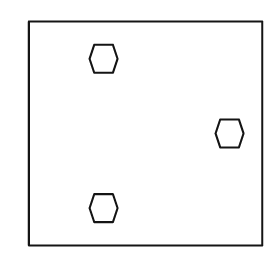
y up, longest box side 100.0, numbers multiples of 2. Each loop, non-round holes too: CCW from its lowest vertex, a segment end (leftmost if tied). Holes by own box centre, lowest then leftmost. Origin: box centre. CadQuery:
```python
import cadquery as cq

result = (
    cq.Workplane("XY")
    .moveTo(-50.0, -48.0)
    .lineTo(50.0, -48.0)
    .lineTo(50.0, 48.0)
    .lineTo(-50.0, 48.0)
    .close()
    .moveTo(-22.0, -38.0)
    .lineTo(-14.0, -38.0)
    .lineTo(-12.0, -32.0)
    .lineTo(-14.0, -26.0)
    .lineTo(-22.0, -26.0)
    .lineTo(-24.0, -32.0)
    .close()
    .moveTo(32.0, -6.0)
    .lineTo(40.0, -6.0)
    .lineTo(42.0, 0.0)
    .lineTo(40.0, 6.0)
    .lineTo(32.0, 6.0)
    .lineTo(30.0, 0.0)
    .close()
    .moveTo(-22.0, 26.0)
    .lineTo(-14.0, 26.0)
    .lineTo(-12.0, 32.0)
    .lineTo(-14.0, 38.0)
    .lineTo(-22.0, 38.0)
    .lineTo(-24.0, 32.0)
    .close()
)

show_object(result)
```